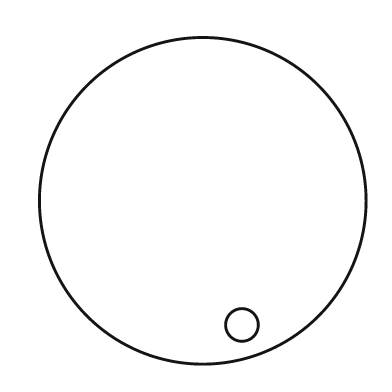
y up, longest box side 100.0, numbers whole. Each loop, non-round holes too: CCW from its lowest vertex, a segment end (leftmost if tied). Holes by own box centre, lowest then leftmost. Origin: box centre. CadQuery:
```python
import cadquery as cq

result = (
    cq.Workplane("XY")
    .moveTo(0.0, 0.0)
    .circle(50.0)
    .moveTo(12.0, -38.0)
    .circle(5.0)
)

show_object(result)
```